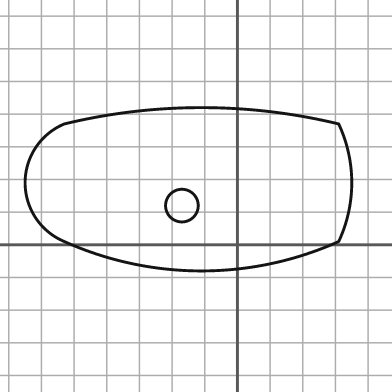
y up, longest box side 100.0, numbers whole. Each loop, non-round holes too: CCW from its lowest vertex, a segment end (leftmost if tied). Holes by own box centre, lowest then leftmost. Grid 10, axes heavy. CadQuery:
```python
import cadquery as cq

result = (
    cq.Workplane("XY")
    .moveTo(-53.0, 1.0)
    .threePointArc((-11.0, -8.0), (31.0, 1.0))
    .threePointArc((35.0, 19.0), (31.0, 37.0))
    .threePointArc((-11.0, 42.0), (-53.0, 37.0))
    .threePointArc((-65.0, 19.0), (-53.0, 1.0))
    .close()
    .moveTo(-17.0, 12.0)
    .circle(5.0)
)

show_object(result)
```